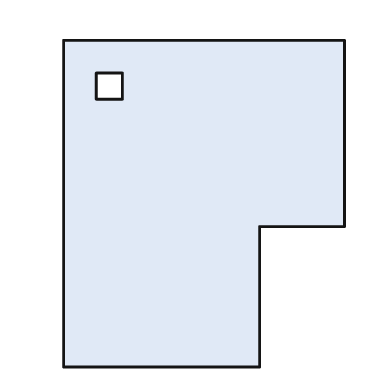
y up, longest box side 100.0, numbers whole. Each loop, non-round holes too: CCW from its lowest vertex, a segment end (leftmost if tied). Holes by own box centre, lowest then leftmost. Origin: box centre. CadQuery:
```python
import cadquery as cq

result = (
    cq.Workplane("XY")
    .moveTo(-43.0, -50.0)
    .lineTo(17.0, -50.0)
    .lineTo(17.0, -7.0)
    .lineTo(43.0, -7.0)
    .lineTo(43.0, 50.0)
    .lineTo(-43.0, 50.0)
    .close()
    .moveTo(-33.0, 32.0)
    .lineTo(-25.0, 32.0)
    .lineTo(-25.0, 40.0)
    .lineTo(-33.0, 40.0)
    .close()
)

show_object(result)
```